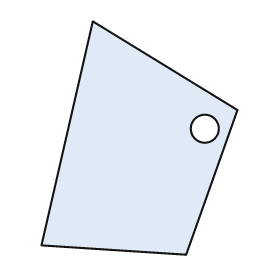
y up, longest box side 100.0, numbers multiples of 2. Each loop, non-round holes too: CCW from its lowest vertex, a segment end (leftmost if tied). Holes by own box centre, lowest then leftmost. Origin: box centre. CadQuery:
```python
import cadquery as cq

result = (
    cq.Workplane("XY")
    .moveTo(20.0, -50.0)
    .lineTo(42.0, 12.0)
    .lineTo(-20.0, 50.0)
    .lineTo(-42.0, -46.0)
    .close()
    .moveTo(28.0, 4.0)
    .circle(6.0)
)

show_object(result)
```